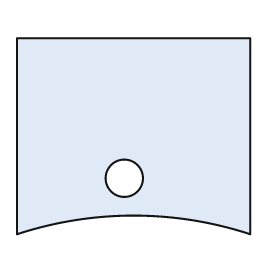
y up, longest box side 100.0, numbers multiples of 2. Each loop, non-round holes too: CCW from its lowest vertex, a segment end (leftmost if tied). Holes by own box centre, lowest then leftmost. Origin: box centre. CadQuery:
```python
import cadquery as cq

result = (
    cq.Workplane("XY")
    .moveTo(-50.0, -42.0)
    .threePointArc((0.0, -34.0), (50.0, -42.0))
    .lineTo(50.0, 42.0)
    .lineTo(-50.0, 42.0)
    .close()
    .moveTo(-4.0, -18.0)
    .circle(8.0)
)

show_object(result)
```